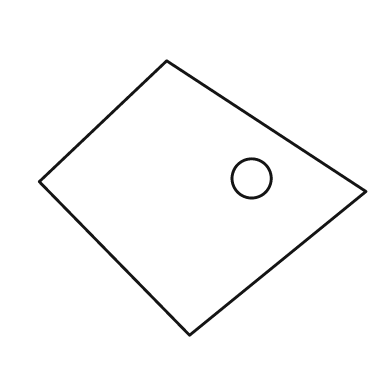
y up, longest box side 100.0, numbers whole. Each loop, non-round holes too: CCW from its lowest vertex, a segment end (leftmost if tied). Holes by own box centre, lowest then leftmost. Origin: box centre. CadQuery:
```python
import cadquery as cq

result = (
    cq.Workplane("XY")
    .moveTo(-4.0, -42.0)
    .lineTo(50.0, 2.0)
    .lineTo(-11.0, 42.0)
    .lineTo(-50.0, 5.0)
    .close()
    .moveTo(15.0, 6.0)
    .circle(6.0)
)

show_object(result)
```